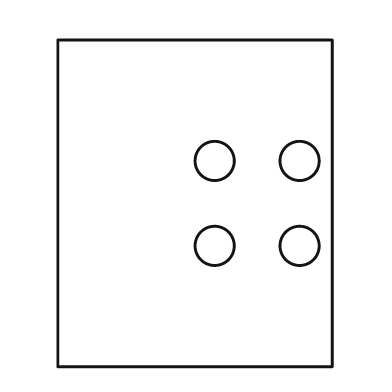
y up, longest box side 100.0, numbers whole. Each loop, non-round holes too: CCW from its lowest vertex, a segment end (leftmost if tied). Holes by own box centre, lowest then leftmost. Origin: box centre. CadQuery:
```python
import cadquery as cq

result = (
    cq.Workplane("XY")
    .moveTo(-42.0, -50.0)
    .lineTo(42.0, -50.0)
    .lineTo(42.0, 50.0)
    .lineTo(-42.0, 50.0)
    .close()
    .moveTo(6.0, -13.0)
    .circle(6.0)
    .moveTo(32.0, -13.0)
    .circle(6.0)
    .moveTo(6.0, 13.0)
    .circle(6.0)
    .moveTo(32.0, 13.0)
    .circle(6.0)
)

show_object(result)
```